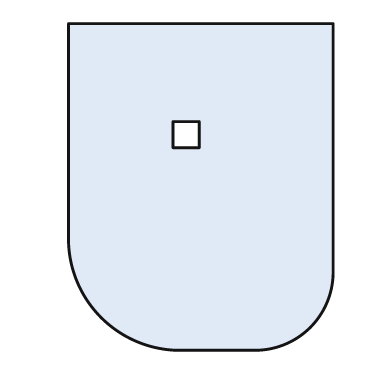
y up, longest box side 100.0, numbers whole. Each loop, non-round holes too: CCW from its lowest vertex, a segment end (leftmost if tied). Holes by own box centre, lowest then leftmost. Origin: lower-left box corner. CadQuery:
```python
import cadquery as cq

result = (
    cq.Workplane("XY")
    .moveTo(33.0, 0.0)
    .lineTo(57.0, 0.0)
    .threePointArc((74.0, 7.0), (81.0, 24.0))
    .lineTo(81.0, 100.0)
    .lineTo(0.0, 100.0)
    .lineTo(0.0, 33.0)
    .threePointArc((10.0, 10.0), (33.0, 0.0))
    .close()
    .moveTo(32.0, 62.0)
    .lineTo(40.0, 62.0)
    .lineTo(40.0, 70.0)
    .lineTo(32.0, 70.0)
    .close()
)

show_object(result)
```